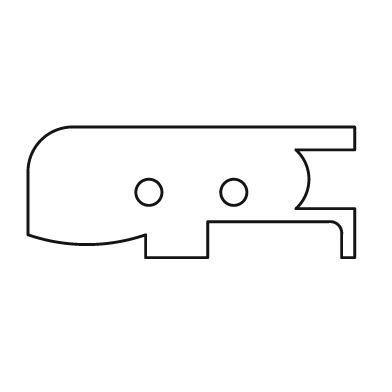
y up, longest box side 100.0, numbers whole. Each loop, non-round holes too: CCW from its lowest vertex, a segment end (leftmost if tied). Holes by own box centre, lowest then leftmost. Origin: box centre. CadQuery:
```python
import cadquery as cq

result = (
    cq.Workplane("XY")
    .moveTo(-14.0, -20.0)
    .lineTo(5.0, -20.0)
    .lineTo(5.0, -9.0)
    .lineTo(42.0, -9.0)
    .threePointArc((45.0, -10.0), (46.0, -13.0))
    .lineTo(46.0, -20.0)
    .lineTo(50.0, -20.0)
    .lineTo(50.0, -5.0)
    .lineTo(32.0, -5.0)
    .threePointArc((36.0, 4.0), (32.0, 13.0))
    .lineTo(50.0, 13.0)
    .lineTo(50.0, 20.0)
    .lineTo(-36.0, 20.0)
    .threePointArc((-46.0, 16.0), (-50.0, 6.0))
    .lineTo(-50.0, -13.0)
    .threePointArc((-32.0, -16.0), (-14.0, -13.0))
    .close()
    .moveTo(-13.0, 0.0)
    .circle(4.0)
    .moveTo(13.0, 0.0)
    .circle(4.0)
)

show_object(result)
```